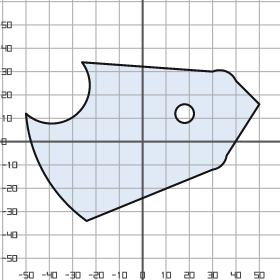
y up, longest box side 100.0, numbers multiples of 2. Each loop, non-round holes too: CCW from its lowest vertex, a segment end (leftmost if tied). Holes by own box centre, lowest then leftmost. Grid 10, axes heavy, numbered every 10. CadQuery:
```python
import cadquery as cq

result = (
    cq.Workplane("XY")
    .moveTo(-24.0, -34.0)
    .lineTo(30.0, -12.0)
    .threePointArc((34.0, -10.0), (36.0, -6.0))
    .lineTo(50.0, 16.0)
    .lineTo(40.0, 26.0)
    .threePointArc((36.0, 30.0), (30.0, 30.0))
    .lineTo(-26.0, 34.0)
    .threePointArc((-28.0, 12.0), (-50.0, 12.0))
    .threePointArc((-42.0, -14.0), (-24.0, -34.0))
    .close()
    .moveTo(18.0, 12.0)
    .circle(4.0)
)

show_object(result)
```